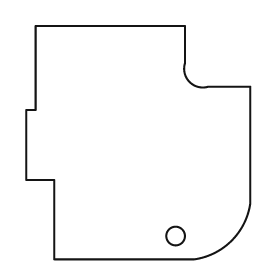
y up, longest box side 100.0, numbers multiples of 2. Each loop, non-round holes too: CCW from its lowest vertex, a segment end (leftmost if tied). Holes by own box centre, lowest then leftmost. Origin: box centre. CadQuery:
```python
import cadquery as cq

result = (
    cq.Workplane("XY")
    .moveTo(-36.0, -50.0)
    .lineTo(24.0, -50.0)
    .threePointArc((40.0, -42.0), (48.0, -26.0))
    .lineTo(48.0, 24.0)
    .lineTo(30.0, 24.0)
    .threePointArc((22.0, 26.0), (20.0, 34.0))
    .lineTo(20.0, 50.0)
    .lineTo(-44.0, 50.0)
    .lineTo(-44.0, 14.0)
    .lineTo(-48.0, 14.0)
    .lineTo(-48.0, -16.0)
    .lineTo(-36.0, -16.0)
    .close()
    .moveTo(16.0, -40.0)
    .circle(4.0)
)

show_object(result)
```